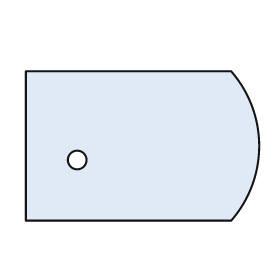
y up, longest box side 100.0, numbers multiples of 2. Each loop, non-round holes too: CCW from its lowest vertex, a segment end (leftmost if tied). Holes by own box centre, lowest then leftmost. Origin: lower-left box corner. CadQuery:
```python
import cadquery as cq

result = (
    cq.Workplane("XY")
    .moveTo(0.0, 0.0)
    .lineTo(88.0, 0.0)
    .threePointArc((100.0, 32.0), (88.0, 64.0))
    .lineTo(0.0, 64.0)
    .close()
    .moveTo(22.0, 26.0)
    .circle(4.0)
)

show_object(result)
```